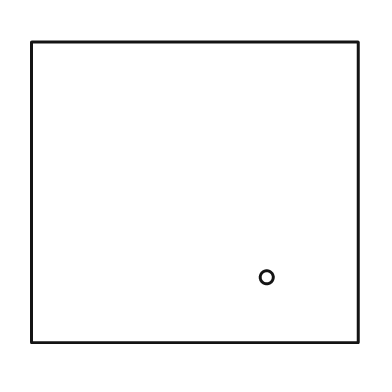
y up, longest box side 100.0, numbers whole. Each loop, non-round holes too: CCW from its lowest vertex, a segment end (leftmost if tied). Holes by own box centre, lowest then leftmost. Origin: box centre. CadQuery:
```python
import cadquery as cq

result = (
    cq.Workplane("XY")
    .moveTo(-50.0, -46.0)
    .lineTo(50.0, -46.0)
    .lineTo(50.0, 46.0)
    .lineTo(-50.0, 46.0)
    .close()
    .moveTo(22.0, -26.0)
    .circle(2.0)
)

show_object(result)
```